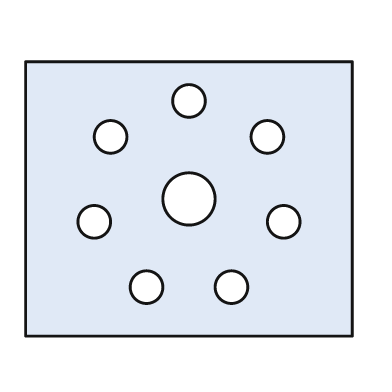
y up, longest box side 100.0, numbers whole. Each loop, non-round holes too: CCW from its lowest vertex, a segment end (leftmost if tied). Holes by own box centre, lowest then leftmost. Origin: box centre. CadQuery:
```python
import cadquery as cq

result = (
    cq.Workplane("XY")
    .moveTo(-50.0, -42.0)
    .lineTo(50.0, -42.0)
    .lineTo(50.0, 42.0)
    .lineTo(-50.0, 42.0)
    .close()
    .moveTo(-13.0, -27.0)
    .circle(5.0)
    .moveTo(13.0, -27.0)
    .circle(5.0)
    .moveTo(-29.0, -7.0)
    .circle(5.0)
    .moveTo(29.0, -7.0)
    .circle(5.0)
    .moveTo(0.0, 0.0)
    .circle(8.0)
    .moveTo(-24.0, 19.0)
    .circle(5.0)
    .moveTo(24.0, 19.0)
    .circle(5.0)
    .moveTo(0.0, 30.0)
    .circle(5.0)
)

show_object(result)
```